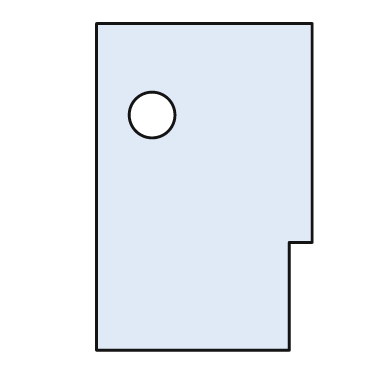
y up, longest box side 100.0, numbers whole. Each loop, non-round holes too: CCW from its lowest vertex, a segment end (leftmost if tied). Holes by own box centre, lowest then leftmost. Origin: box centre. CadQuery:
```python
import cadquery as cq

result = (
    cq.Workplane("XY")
    .moveTo(-33.0, -50.0)
    .lineTo(26.0, -50.0)
    .lineTo(26.0, -17.0)
    .lineTo(33.0, -17.0)
    .lineTo(33.0, 50.0)
    .lineTo(-33.0, 50.0)
    .close()
    .moveTo(-16.0, 22.0)
    .circle(7.0)
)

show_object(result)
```